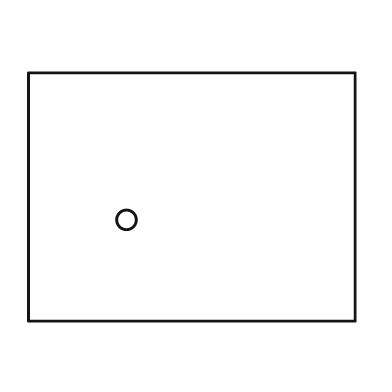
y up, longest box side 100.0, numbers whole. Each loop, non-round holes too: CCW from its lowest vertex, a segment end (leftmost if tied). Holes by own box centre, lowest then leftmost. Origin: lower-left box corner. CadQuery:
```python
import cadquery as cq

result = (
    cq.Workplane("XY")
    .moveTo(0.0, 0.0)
    .lineTo(100.0, 0.0)
    .lineTo(100.0, 76.0)
    .lineTo(0.0, 76.0)
    .close()
    .moveTo(30.0, 31.0)
    .circle(3.0)
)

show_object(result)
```